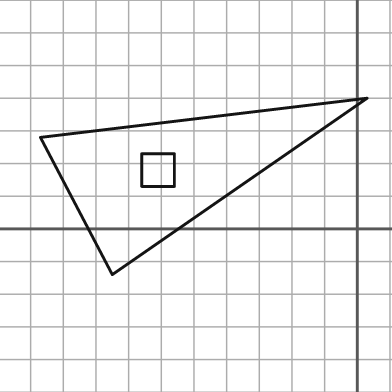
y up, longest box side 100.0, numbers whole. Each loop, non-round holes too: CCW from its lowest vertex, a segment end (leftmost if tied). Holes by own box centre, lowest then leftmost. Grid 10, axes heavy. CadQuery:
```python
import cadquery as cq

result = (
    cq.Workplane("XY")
    .moveTo(-75.0, -14.0)
    .lineTo(3.0, 40.0)
    .lineTo(-97.0, 28.0)
    .close()
    .moveTo(-66.0, 13.0)
    .lineTo(-56.0, 13.0)
    .lineTo(-56.0, 23.0)
    .lineTo(-66.0, 23.0)
    .close()
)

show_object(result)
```